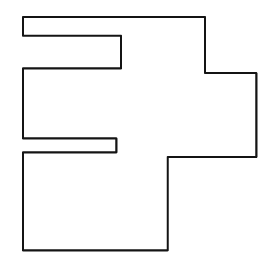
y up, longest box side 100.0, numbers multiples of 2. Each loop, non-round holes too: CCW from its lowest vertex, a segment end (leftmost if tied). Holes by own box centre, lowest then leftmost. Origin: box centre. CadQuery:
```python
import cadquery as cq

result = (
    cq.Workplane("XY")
    .moveTo(-50.0, -50.0)
    .lineTo(12.0, -50.0)
    .lineTo(12.0, -10.0)
    .lineTo(50.0, -10.0)
    .lineTo(50.0, 26.0)
    .lineTo(28.0, 26.0)
    .lineTo(28.0, 50.0)
    .lineTo(-50.0, 50.0)
    .lineTo(-50.0, 42.0)
    .lineTo(-8.0, 42.0)
    .lineTo(-8.0, 28.0)
    .lineTo(-50.0, 28.0)
    .lineTo(-50.0, -2.0)
    .lineTo(-10.0, -2.0)
    .lineTo(-10.0, -8.0)
    .lineTo(-50.0, -8.0)
    .close()
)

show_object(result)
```